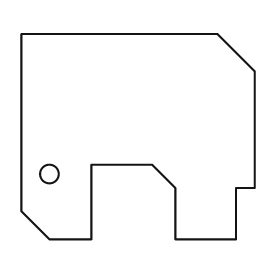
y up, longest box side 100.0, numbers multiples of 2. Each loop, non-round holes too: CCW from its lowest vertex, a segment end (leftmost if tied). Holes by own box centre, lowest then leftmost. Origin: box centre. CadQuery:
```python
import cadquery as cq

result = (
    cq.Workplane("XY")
    .moveTo(-38.0, -44.0)
    .lineTo(-20.0, -44.0)
    .lineTo(-20.0, -12.0)
    .lineTo(6.0, -12.0)
    .lineTo(16.0, -22.0)
    .lineTo(16.0, -44.0)
    .lineTo(42.0, -44.0)
    .lineTo(42.0, -22.0)
    .lineTo(50.0, -22.0)
    .lineTo(50.0, 28.0)
    .lineTo(34.0, 44.0)
    .lineTo(-50.0, 44.0)
    .lineTo(-50.0, -32.0)
    .close()
    .moveTo(-38.0, -16.0)
    .circle(4.0)
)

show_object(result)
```